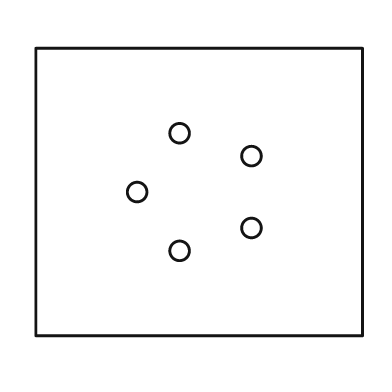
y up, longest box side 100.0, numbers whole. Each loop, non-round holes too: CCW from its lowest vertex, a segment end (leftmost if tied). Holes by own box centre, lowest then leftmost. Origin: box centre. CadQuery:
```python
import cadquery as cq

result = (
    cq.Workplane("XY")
    .moveTo(-50.0, -44.0)
    .lineTo(50.0, -44.0)
    .lineTo(50.0, 44.0)
    .lineTo(-50.0, 44.0)
    .close()
    .moveTo(-6.0, -18.0)
    .circle(3.0)
    .moveTo(16.0, -11.0)
    .circle(3.0)
    .moveTo(-19.0, 0.0)
    .circle(3.0)
    .moveTo(16.0, 11.0)
    .circle(3.0)
    .moveTo(-6.0, 18.0)
    .circle(3.0)
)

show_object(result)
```